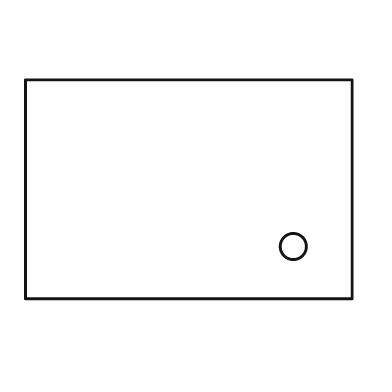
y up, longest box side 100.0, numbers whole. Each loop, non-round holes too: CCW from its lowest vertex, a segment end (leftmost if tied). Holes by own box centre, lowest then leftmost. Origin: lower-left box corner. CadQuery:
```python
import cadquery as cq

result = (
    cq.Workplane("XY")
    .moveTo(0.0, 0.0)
    .lineTo(100.0, 0.0)
    .lineTo(100.0, 67.0)
    .lineTo(0.0, 67.0)
    .close()
    .moveTo(82.0, 16.0)
    .circle(4.0)
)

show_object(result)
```